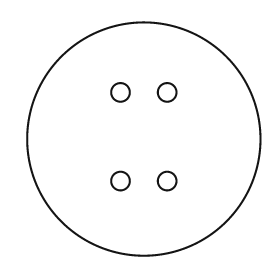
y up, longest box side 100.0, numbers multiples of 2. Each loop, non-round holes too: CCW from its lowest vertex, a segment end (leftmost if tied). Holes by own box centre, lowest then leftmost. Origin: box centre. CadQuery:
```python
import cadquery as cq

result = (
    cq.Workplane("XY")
    .moveTo(0.0, 0.0)
    .circle(50.0)
    .moveTo(-10.0, -18.0)
    .circle(4.0)
    .moveTo(10.0, -18.0)
    .circle(4.0)
    .moveTo(-10.0, 20.0)
    .circle(4.0)
    .moveTo(10.0, 20.0)
    .circle(4.0)
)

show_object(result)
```